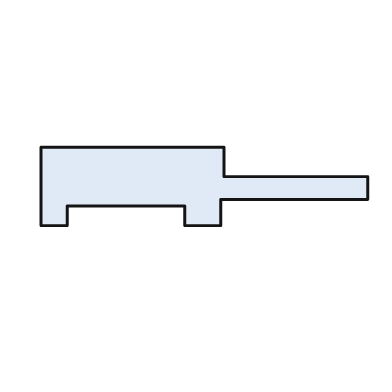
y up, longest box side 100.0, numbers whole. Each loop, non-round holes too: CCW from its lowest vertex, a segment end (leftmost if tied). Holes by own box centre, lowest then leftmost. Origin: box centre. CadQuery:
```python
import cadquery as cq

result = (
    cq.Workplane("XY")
    .moveTo(-50.0, -12.0)
    .lineTo(-42.0, -12.0)
    .lineTo(-42.0, -6.0)
    .lineTo(-6.0, -6.0)
    .lineTo(-6.0, -12.0)
    .lineTo(5.0, -12.0)
    .lineTo(5.0, -4.0)
    .lineTo(50.0, -4.0)
    .lineTo(50.0, 3.0)
    .lineTo(6.0, 3.0)
    .lineTo(6.0, 12.0)
    .lineTo(-50.0, 12.0)
    .close()
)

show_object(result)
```